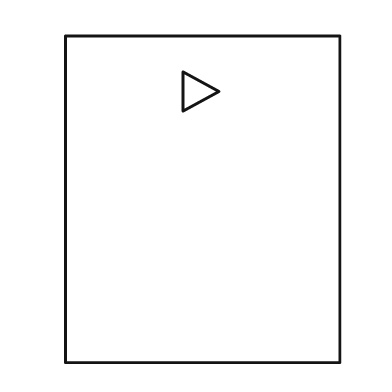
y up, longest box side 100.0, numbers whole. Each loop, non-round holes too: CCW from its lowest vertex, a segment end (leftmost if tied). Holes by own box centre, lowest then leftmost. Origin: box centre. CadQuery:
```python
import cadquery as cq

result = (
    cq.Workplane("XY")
    .moveTo(-42.0, -50.0)
    .lineTo(42.0, -50.0)
    .lineTo(42.0, 50.0)
    .lineTo(-42.0, 50.0)
    .close()
    .moveTo(-6.0, 27.0)
    .lineTo(5.0, 33.0)
    .lineTo(-6.0, 39.0)
    .close()
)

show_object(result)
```